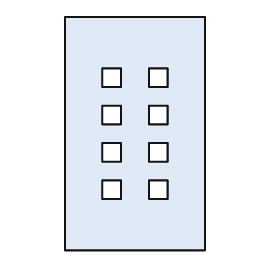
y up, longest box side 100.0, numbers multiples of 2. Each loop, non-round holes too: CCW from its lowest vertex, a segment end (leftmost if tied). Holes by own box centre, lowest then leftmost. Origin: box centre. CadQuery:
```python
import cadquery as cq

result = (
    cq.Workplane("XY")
    .moveTo(-30.0, -50.0)
    .lineTo(30.0, -50.0)
    .lineTo(30.0, 50.0)
    .lineTo(-30.0, 50.0)
    .close()
    .moveTo(-14.0, -28.0)
    .lineTo(-6.0, -28.0)
    .lineTo(-6.0, -20.0)
    .lineTo(-14.0, -20.0)
    .close()
    .moveTo(6.0, -28.0)
    .lineTo(14.0, -28.0)
    .lineTo(14.0, -20.0)
    .lineTo(6.0, -20.0)
    .close()
    .moveTo(-14.0, -12.0)
    .lineTo(-6.0, -12.0)
    .lineTo(-6.0, -4.0)
    .lineTo(-14.0, -4.0)
    .close()
    .moveTo(6.0, -12.0)
    .lineTo(14.0, -12.0)
    .lineTo(14.0, -4.0)
    .lineTo(6.0, -4.0)
    .close()
    .moveTo(-14.0, 4.0)
    .lineTo(-6.0, 4.0)
    .lineTo(-6.0, 12.0)
    .lineTo(-14.0, 12.0)
    .close()
    .moveTo(6.0, 4.0)
    .lineTo(14.0, 4.0)
    .lineTo(14.0, 12.0)
    .lineTo(6.0, 12.0)
    .close()
    .moveTo(-14.0, 20.0)
    .lineTo(-6.0, 20.0)
    .lineTo(-6.0, 28.0)
    .lineTo(-14.0, 28.0)
    .close()
    .moveTo(6.0, 20.0)
    .lineTo(14.0, 20.0)
    .lineTo(14.0, 28.0)
    .lineTo(6.0, 28.0)
    .close()
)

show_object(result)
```